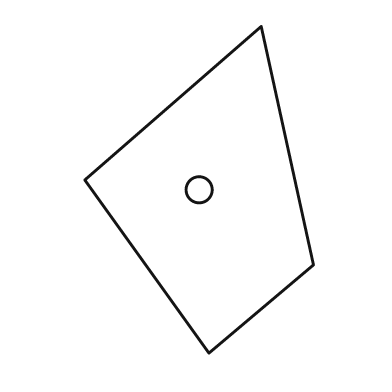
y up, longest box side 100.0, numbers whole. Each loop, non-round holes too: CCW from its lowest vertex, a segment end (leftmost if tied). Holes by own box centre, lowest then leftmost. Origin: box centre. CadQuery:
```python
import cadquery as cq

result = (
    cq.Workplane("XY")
    .moveTo(3.0, -50.0)
    .lineTo(35.0, -23.0)
    .lineTo(19.0, 50.0)
    .lineTo(-35.0, 3.0)
    .close()
    .moveTo(0.0, 0.0)
    .circle(4.0)
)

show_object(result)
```